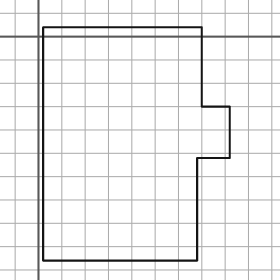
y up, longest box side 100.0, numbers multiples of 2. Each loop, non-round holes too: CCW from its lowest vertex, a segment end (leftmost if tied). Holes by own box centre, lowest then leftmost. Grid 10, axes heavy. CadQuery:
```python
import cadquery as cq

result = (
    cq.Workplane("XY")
    .moveTo(2.0, -96.0)
    .lineTo(68.0, -96.0)
    .lineTo(68.0, -52.0)
    .lineTo(82.0, -52.0)
    .lineTo(82.0, -30.0)
    .lineTo(70.0, -30.0)
    .lineTo(70.0, 4.0)
    .lineTo(2.0, 4.0)
    .close()
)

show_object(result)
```